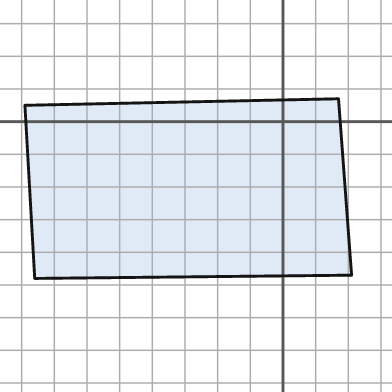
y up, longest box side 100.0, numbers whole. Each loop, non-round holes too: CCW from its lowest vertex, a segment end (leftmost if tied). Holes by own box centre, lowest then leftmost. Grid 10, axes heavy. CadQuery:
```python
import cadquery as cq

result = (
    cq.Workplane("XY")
    .moveTo(-76.0, -48.0)
    .lineTo(21.0, -47.0)
    .lineTo(17.0, 7.0)
    .lineTo(-79.0, 5.0)
    .close()
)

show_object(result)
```